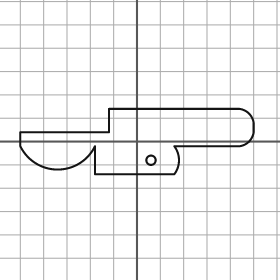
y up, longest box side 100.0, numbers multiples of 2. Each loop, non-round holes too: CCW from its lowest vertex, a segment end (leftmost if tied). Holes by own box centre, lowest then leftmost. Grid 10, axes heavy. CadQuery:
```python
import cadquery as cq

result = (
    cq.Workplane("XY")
    .moveTo(-18.0, -14.0)
    .lineTo(16.0, -14.0)
    .threePointArc((18.0, -8.0), (16.0, -2.0))
    .lineTo(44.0, -2.0)
    .threePointArc((48.0, 0.0), (50.0, 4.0))
    .lineTo(50.0, 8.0)
    .threePointArc((48.0, 12.0), (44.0, 14.0))
    .lineTo(-12.0, 14.0)
    .lineTo(-12.0, 4.0)
    .lineTo(-50.0, 4.0)
    .lineTo(-50.0, -2.0)
    .threePointArc((-34.0, -12.0), (-18.0, -2.0))
    .close()
    .moveTo(6.0, -8.0)
    .circle(2.0)
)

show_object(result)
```